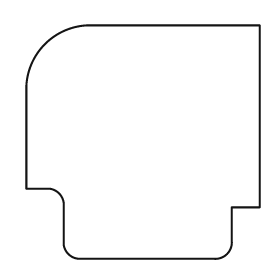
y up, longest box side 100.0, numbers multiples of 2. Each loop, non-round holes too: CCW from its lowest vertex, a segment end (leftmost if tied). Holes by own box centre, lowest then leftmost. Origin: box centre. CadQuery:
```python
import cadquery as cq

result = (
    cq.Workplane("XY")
    .moveTo(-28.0, -50.0)
    .lineTo(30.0, -50.0)
    .threePointArc((36.0, -48.0), (38.0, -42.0))
    .lineTo(38.0, -28.0)
    .lineTo(50.0, -28.0)
    .lineTo(50.0, 50.0)
    .lineTo(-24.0, 50.0)
    .threePointArc((-42.0, 42.0), (-50.0, 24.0))
    .lineTo(-50.0, -20.0)
    .lineTo(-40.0, -20.0)
    .threePointArc((-36.0, -22.0), (-34.0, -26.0))
    .lineTo(-34.0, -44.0)
    .threePointArc((-32.0, -48.0), (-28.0, -50.0))
    .close()
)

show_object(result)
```